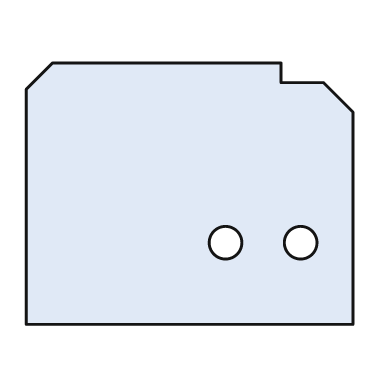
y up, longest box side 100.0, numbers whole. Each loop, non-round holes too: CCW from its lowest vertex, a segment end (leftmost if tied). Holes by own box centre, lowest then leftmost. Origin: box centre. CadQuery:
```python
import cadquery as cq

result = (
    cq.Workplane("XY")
    .moveTo(-50.0, -40.0)
    .lineTo(50.0, -40.0)
    .lineTo(50.0, 25.0)
    .lineTo(41.0, 34.0)
    .lineTo(28.0, 34.0)
    .lineTo(28.0, 40.0)
    .lineTo(-42.0, 40.0)
    .lineTo(-50.0, 32.0)
    .close()
    .moveTo(11.0, -15.0)
    .circle(5.0)
    .moveTo(34.0, -15.0)
    .circle(5.0)
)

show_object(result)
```